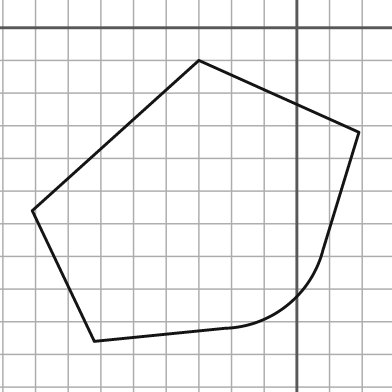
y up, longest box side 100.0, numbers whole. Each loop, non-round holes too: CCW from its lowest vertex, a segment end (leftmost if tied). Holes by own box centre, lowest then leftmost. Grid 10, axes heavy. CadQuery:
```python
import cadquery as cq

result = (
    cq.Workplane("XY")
    .moveTo(-62.0, -96.0)
    .lineTo(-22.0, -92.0)
    .threePointArc((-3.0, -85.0), (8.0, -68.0))
    .lineTo(19.0, -32.0)
    .lineTo(-30.0, -10.0)
    .lineTo(-81.0, -56.0)
    .close()
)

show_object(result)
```